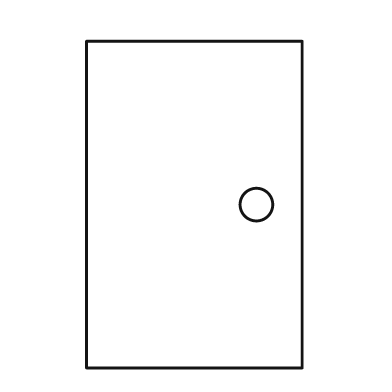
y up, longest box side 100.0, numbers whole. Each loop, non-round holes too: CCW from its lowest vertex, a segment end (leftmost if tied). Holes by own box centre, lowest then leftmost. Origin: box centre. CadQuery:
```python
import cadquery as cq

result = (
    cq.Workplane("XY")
    .moveTo(-33.0, -50.0)
    .lineTo(33.0, -50.0)
    .lineTo(33.0, 50.0)
    .lineTo(-33.0, 50.0)
    .close()
    .moveTo(19.0, 0.0)
    .circle(5.0)
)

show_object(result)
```